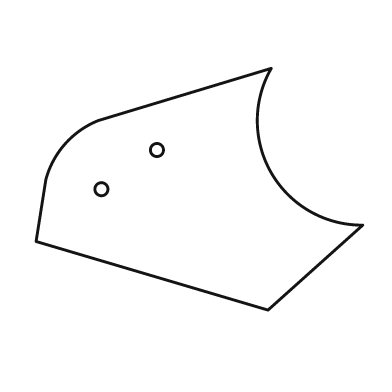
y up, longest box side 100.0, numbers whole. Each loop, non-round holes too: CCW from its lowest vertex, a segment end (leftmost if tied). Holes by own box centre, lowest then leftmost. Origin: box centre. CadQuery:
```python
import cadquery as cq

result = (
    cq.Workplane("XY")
    .moveTo(21.0, -37.0)
    .lineTo(50.0, -11.0)
    .threePointArc((22.0, 5.0), (22.0, 37.0))
    .lineTo(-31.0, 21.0)
    .threePointArc((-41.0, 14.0), (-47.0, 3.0))
    .lineTo(-50.0, -16.0)
    .close()
    .moveTo(-30.0, 0.0)
    .circle(2.0)
    .moveTo(-13.0, 12.0)
    .circle(2.0)
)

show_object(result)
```